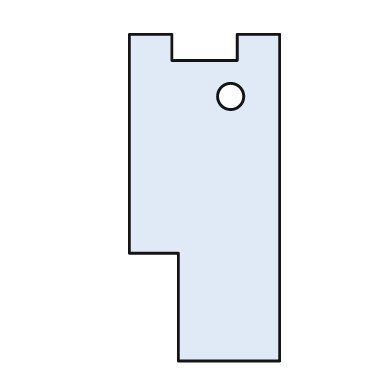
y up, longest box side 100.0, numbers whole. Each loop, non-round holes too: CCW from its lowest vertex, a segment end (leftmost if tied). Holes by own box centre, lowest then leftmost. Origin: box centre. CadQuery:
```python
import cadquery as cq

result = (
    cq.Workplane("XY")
    .moveTo(-8.0, -50.0)
    .lineTo(23.0, -50.0)
    .lineTo(23.0, 50.0)
    .lineTo(10.0, 50.0)
    .lineTo(10.0, 42.0)
    .lineTo(-10.0, 42.0)
    .lineTo(-10.0, 50.0)
    .lineTo(-23.0, 50.0)
    .lineTo(-23.0, -17.0)
    .lineTo(-8.0, -17.0)
    .close()
    .moveTo(8.0, 31.0)
    .circle(4.0)
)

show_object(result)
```